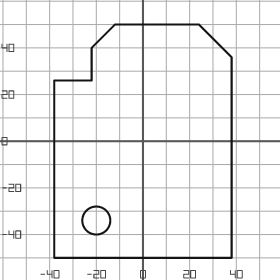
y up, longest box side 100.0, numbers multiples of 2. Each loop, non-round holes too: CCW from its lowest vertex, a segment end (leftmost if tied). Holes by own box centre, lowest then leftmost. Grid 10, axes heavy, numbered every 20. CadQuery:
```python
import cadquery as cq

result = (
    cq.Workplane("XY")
    .moveTo(-38.0, -50.0)
    .lineTo(38.0, -50.0)
    .lineTo(38.0, 36.0)
    .lineTo(24.0, 50.0)
    .lineTo(-12.0, 50.0)
    .lineTo(-22.0, 40.0)
    .lineTo(-22.0, 26.0)
    .lineTo(-38.0, 26.0)
    .close()
    .moveTo(-20.0, -34.0)
    .circle(6.0)
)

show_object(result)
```